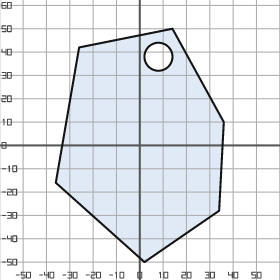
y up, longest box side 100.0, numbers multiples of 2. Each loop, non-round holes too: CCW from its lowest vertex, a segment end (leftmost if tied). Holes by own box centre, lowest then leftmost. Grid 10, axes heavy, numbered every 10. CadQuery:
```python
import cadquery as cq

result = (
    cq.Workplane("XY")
    .moveTo(2.0, -50.0)
    .lineTo(34.0, -28.0)
    .lineTo(36.0, 10.0)
    .lineTo(14.0, 50.0)
    .lineTo(-26.0, 42.0)
    .lineTo(-36.0, -16.0)
    .close()
    .moveTo(8.0, 38.0)
    .circle(6.0)
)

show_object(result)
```